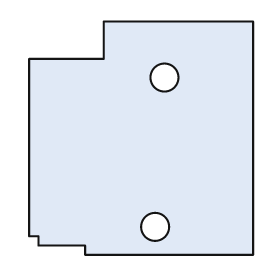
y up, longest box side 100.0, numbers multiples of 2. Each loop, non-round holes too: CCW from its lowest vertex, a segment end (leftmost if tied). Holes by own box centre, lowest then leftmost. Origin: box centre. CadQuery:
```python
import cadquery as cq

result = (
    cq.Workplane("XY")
    .moveTo(-24.0, -50.0)
    .lineTo(48.0, -50.0)
    .lineTo(48.0, 50.0)
    .lineTo(-16.0, 50.0)
    .lineTo(-16.0, 34.0)
    .lineTo(-48.0, 34.0)
    .lineTo(-48.0, -42.0)
    .lineTo(-44.0, -42.0)
    .lineTo(-44.0, -46.0)
    .lineTo(-24.0, -46.0)
    .close()
    .moveTo(6.0, -38.0)
    .circle(6.0)
    .moveTo(10.0, 26.0)
    .circle(6.0)
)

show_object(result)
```